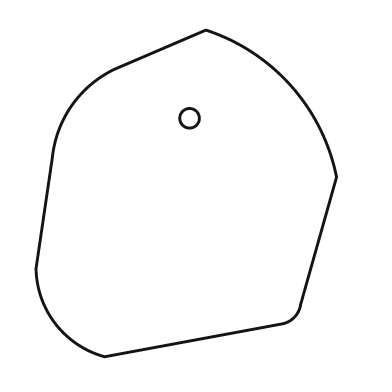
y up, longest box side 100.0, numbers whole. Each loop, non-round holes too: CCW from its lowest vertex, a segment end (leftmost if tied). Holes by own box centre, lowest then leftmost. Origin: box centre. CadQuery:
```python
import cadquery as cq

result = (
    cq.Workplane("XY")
    .moveTo(-25.0, -50.0)
    .lineTo(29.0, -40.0)
    .threePointArc((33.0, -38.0), (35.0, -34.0))
    .lineTo(46.0, 5.0)
    .threePointArc((32.0, 33.0), (6.0, 50.0))
    .lineTo(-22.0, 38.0)
    .threePointArc((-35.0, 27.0), (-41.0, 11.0))
    .lineTo(-46.0, -23.0)
    .threePointArc((-40.0, -40.0), (-25.0, -50.0))
    .close()
    .moveTo(1.0, 23.0)
    .circle(3.0)
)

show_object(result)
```